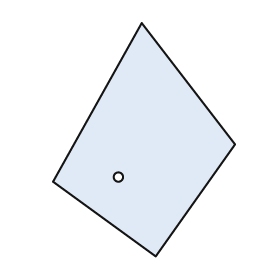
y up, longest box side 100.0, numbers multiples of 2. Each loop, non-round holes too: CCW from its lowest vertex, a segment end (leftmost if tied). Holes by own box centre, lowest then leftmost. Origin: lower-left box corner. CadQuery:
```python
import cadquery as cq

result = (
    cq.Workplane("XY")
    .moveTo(44.0, 0.0)
    .lineTo(78.0, 48.0)
    .lineTo(38.0, 100.0)
    .lineTo(0.0, 32.0)
    .close()
    .moveTo(28.0, 34.0)
    .circle(2.0)
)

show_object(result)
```